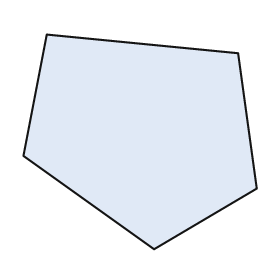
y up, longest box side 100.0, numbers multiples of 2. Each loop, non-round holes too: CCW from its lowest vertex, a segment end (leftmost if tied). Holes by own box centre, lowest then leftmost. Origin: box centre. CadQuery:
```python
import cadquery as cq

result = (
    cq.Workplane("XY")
    .moveTo(6.0, -46.0)
    .lineTo(50.0, -20.0)
    .lineTo(42.0, 38.0)
    .lineTo(-40.0, 46.0)
    .lineTo(-50.0, -6.0)
    .close()
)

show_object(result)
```